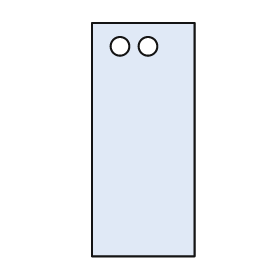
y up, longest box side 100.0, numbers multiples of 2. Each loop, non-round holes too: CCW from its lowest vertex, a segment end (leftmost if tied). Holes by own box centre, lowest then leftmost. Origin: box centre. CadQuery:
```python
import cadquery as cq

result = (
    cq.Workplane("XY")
    .moveTo(-22.0, -50.0)
    .lineTo(22.0, -50.0)
    .lineTo(22.0, 50.0)
    .lineTo(-22.0, 50.0)
    .close()
    .moveTo(-10.0, 40.0)
    .circle(4.0)
    .moveTo(2.0, 40.0)
    .circle(4.0)
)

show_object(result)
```